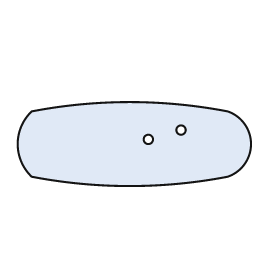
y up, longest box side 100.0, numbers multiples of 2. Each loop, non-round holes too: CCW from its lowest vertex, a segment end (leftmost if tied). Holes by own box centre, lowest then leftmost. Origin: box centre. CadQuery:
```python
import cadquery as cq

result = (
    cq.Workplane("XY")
    .moveTo(-44.0, -14.0)
    .threePointArc((-2.0, -18.0), (40.0, -14.0))
    .threePointArc((50.0, 0.0), (40.0, 14.0))
    .threePointArc((-2.0, 18.0), (-44.0, 14.0))
    .threePointArc((-50.0, 0.0), (-44.0, -14.0))
    .close()
    .moveTo(6.0, 2.0)
    .circle(2.0)
    .moveTo(20.0, 6.0)
    .circle(2.0)
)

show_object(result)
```